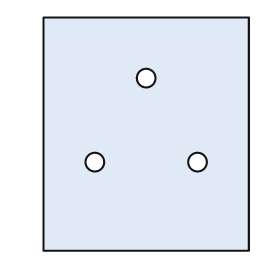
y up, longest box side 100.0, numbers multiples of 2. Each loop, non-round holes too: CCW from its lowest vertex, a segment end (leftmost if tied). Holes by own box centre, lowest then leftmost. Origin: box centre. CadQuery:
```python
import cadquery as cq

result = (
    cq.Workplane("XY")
    .moveTo(-44.0, -50.0)
    .lineTo(44.0, -50.0)
    .lineTo(44.0, 50.0)
    .lineTo(-44.0, 50.0)
    .close()
    .moveTo(-22.0, -12.0)
    .circle(4.0)
    .moveTo(22.0, -12.0)
    .circle(4.0)
    .moveTo(0.0, 24.0)
    .circle(4.0)
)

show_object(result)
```